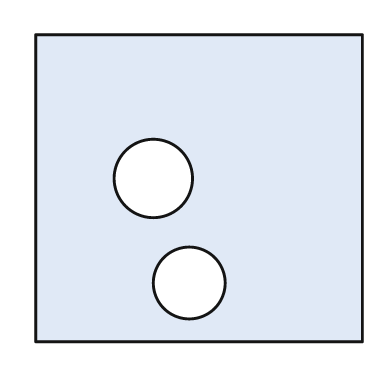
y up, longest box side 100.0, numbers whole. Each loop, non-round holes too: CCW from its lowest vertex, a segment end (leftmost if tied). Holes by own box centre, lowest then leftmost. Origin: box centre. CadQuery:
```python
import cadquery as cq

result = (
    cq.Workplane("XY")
    .moveTo(-50.0, -47.0)
    .lineTo(50.0, -47.0)
    .lineTo(50.0, 47.0)
    .lineTo(-50.0, 47.0)
    .close()
    .moveTo(-3.0, -29.0)
    .circle(11.0)
    .moveTo(-14.0, 3.0)
    .circle(12.0)
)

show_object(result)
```